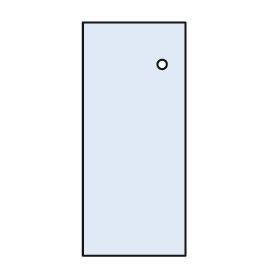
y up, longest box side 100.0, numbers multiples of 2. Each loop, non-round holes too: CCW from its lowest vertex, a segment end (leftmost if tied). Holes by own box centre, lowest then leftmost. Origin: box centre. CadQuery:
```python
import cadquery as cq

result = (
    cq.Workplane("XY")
    .moveTo(-22.0, -50.0)
    .lineTo(22.0, -50.0)
    .lineTo(22.0, 50.0)
    .lineTo(-22.0, 50.0)
    .close()
    .moveTo(12.0, 32.0)
    .circle(2.0)
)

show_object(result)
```